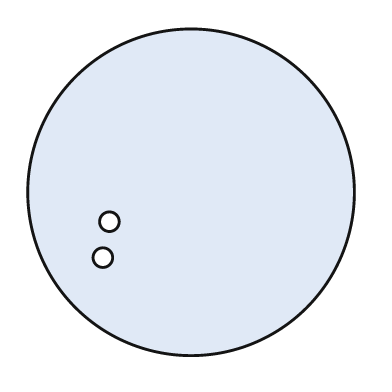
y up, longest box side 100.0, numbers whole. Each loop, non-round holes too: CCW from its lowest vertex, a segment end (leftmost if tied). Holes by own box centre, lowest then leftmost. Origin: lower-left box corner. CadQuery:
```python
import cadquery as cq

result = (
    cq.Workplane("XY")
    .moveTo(50.0, 50.0)
    .circle(50.0)
    .moveTo(23.0, 30.0)
    .circle(3.0)
    .moveTo(25.0, 41.0)
    .circle(3.0)
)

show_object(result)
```